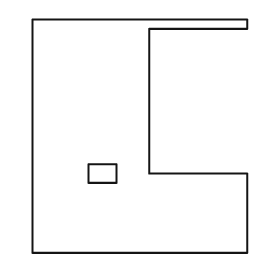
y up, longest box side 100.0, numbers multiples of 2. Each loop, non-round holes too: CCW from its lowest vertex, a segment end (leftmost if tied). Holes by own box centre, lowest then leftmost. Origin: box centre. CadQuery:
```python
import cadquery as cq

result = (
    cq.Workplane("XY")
    .moveTo(-46.0, -50.0)
    .lineTo(46.0, -50.0)
    .lineTo(46.0, -16.0)
    .lineTo(4.0, -16.0)
    .lineTo(4.0, 46.0)
    .lineTo(46.0, 46.0)
    .lineTo(46.0, 50.0)
    .lineTo(-46.0, 50.0)
    .close()
    .moveTo(-22.0, -20.0)
    .lineTo(-10.0, -20.0)
    .lineTo(-10.0, -12.0)
    .lineTo(-22.0, -12.0)
    .close()
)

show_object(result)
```